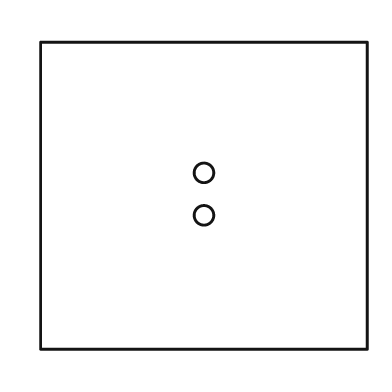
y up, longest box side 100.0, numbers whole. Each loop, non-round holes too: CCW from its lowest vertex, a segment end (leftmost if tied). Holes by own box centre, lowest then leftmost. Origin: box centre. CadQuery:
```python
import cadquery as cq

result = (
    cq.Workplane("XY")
    .moveTo(-50.0, -47.0)
    .lineTo(50.0, -47.0)
    .lineTo(50.0, 47.0)
    .lineTo(-50.0, 47.0)
    .close()
    .moveTo(0.0, -6.0)
    .circle(3.0)
    .moveTo(0.0, 7.0)
    .circle(3.0)
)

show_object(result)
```